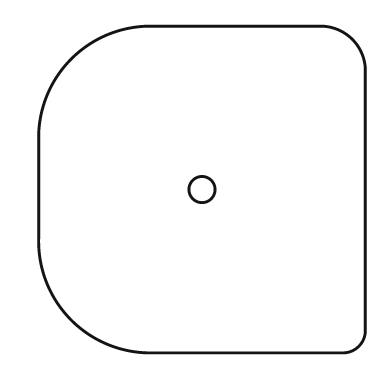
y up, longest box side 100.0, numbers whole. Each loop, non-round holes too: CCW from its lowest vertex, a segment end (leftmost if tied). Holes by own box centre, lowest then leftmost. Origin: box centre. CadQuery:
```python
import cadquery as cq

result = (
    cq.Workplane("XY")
    .moveTo(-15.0, -50.0)
    .lineTo(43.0, -50.0)
    .threePointArc((48.0, -48.0), (50.0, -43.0))
    .lineTo(50.0, 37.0)
    .threePointArc((46.0, 46.0), (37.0, 50.0))
    .lineTo(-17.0, 50.0)
    .threePointArc((-40.0, 40.0), (-50.0, 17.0))
    .lineTo(-50.0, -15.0)
    .threePointArc((-40.0, -40.0), (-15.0, -50.0))
    .close()
    .moveTo(0.0, 0.0)
    .circle(4.0)
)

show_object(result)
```